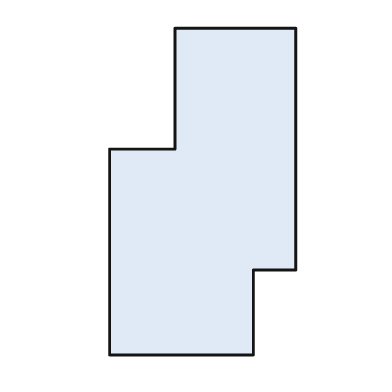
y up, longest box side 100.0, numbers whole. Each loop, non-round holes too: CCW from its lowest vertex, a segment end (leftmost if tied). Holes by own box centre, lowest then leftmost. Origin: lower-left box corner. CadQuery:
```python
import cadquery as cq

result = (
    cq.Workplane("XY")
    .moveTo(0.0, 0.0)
    .lineTo(44.0, 0.0)
    .lineTo(44.0, 26.0)
    .lineTo(57.0, 26.0)
    .lineTo(57.0, 100.0)
    .lineTo(20.0, 100.0)
    .lineTo(20.0, 63.0)
    .lineTo(0.0, 63.0)
    .close()
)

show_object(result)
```